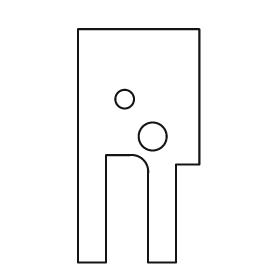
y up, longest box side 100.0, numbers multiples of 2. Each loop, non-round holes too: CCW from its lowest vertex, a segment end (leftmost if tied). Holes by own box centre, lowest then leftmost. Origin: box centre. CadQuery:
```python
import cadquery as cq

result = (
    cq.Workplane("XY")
    .moveTo(-26.0, -50.0)
    .lineTo(-14.0, -50.0)
    .lineTo(-14.0, -4.0)
    .lineTo(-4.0, -4.0)
    .threePointArc((2.0, -6.0), (4.0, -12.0))
    .lineTo(4.0, -50.0)
    .lineTo(16.0, -50.0)
    .lineTo(16.0, -8.0)
    .lineTo(26.0, -8.0)
    .lineTo(26.0, 50.0)
    .lineTo(-26.0, 50.0)
    .close()
    .moveTo(6.0, 4.0)
    .circle(6.0)
    .moveTo(-6.0, 20.0)
    .circle(4.0)
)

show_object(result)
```